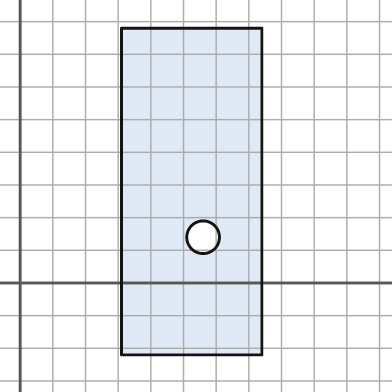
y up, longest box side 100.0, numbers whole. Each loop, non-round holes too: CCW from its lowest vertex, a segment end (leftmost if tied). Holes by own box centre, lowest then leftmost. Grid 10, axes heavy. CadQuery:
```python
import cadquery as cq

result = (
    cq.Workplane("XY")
    .moveTo(31.0, -22.0)
    .lineTo(74.0, -22.0)
    .lineTo(74.0, 78.0)
    .lineTo(31.0, 78.0)
    .close()
    .moveTo(56.0, 14.0)
    .circle(5.0)
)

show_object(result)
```